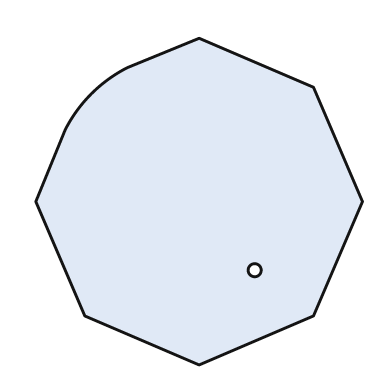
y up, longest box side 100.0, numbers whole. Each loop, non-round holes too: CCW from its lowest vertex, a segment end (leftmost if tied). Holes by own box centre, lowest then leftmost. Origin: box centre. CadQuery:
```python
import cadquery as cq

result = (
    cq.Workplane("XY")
    .moveTo(0.0, -50.0)
    .lineTo(35.0, -35.0)
    .lineTo(50.0, 0.0)
    .lineTo(35.0, 35.0)
    .lineTo(0.0, 50.0)
    .lineTo(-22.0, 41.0)
    .threePointArc((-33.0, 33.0), (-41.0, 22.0))
    .lineTo(-50.0, 0.0)
    .lineTo(-35.0, -35.0)
    .close()
    .moveTo(17.0, -21.0)
    .circle(2.0)
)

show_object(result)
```